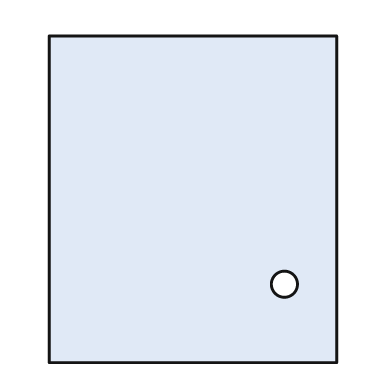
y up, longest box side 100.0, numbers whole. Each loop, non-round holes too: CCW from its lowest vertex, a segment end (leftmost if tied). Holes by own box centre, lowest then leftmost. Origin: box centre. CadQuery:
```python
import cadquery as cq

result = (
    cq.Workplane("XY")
    .moveTo(-44.0, -50.0)
    .lineTo(44.0, -50.0)
    .lineTo(44.0, 50.0)
    .lineTo(-44.0, 50.0)
    .close()
    .moveTo(28.0, -26.0)
    .circle(4.0)
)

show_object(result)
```